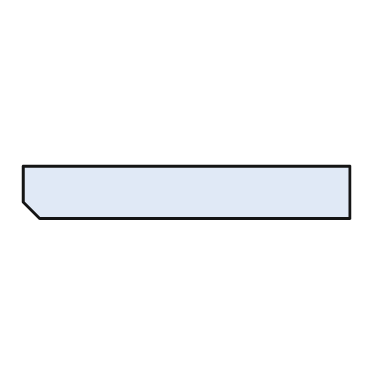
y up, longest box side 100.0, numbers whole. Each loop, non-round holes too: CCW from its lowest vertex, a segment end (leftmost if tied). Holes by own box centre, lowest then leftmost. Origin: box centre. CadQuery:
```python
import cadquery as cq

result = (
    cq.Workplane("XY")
    .moveTo(-45.0, -8.0)
    .lineTo(50.0, -8.0)
    .lineTo(50.0, 8.0)
    .lineTo(-50.0, 8.0)
    .lineTo(-50.0, -3.0)
    .close()
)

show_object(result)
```